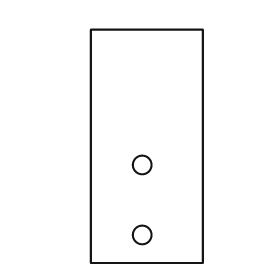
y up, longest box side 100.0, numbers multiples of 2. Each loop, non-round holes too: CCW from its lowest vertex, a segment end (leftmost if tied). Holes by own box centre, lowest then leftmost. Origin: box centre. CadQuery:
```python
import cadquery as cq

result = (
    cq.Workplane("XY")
    .moveTo(-24.0, -50.0)
    .lineTo(24.0, -50.0)
    .lineTo(24.0, 50.0)
    .lineTo(-24.0, 50.0)
    .close()
    .moveTo(-2.0, -38.0)
    .circle(4.0)
    .moveTo(-2.0, -8.0)
    .circle(4.0)
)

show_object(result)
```